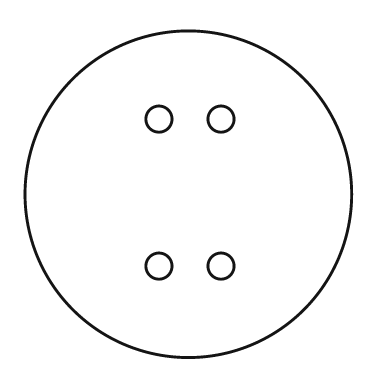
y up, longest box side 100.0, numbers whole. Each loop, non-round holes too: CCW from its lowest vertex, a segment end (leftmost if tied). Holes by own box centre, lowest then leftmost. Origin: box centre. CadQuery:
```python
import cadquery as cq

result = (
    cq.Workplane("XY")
    .moveTo(0.0, 0.0)
    .circle(50.0)
    .moveTo(-9.0, -22.0)
    .circle(4.0)
    .moveTo(10.0, -22.0)
    .circle(4.0)
    .moveTo(-9.0, 23.0)
    .circle(4.0)
    .moveTo(10.0, 23.0)
    .circle(4.0)
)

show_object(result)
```